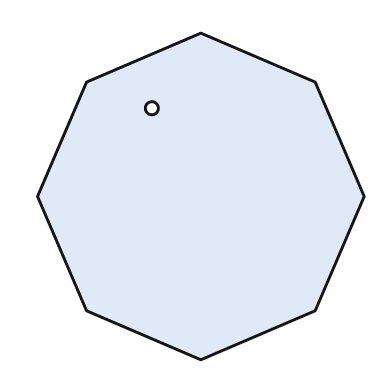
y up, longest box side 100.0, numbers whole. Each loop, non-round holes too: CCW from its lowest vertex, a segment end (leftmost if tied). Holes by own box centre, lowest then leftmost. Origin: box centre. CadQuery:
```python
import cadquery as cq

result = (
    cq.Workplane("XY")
    .moveTo(0.0, -50.0)
    .lineTo(35.0, -35.0)
    .lineTo(50.0, 0.0)
    .lineTo(35.0, 35.0)
    .lineTo(0.0, 50.0)
    .lineTo(-35.0, 35.0)
    .lineTo(-50.0, 0.0)
    .lineTo(-35.0, -35.0)
    .close()
    .moveTo(-15.0, 27.0)
    .circle(2.0)
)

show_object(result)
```